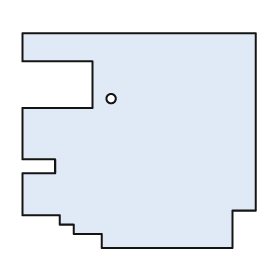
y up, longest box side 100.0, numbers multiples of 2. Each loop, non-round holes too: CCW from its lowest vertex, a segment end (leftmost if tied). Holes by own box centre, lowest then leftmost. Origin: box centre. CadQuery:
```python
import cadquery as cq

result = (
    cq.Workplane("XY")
    .moveTo(-16.0, -46.0)
    .lineTo(40.0, -46.0)
    .lineTo(40.0, -30.0)
    .lineTo(50.0, -30.0)
    .lineTo(50.0, 46.0)
    .lineTo(-50.0, 46.0)
    .lineTo(-50.0, 34.0)
    .lineTo(-20.0, 34.0)
    .lineTo(-20.0, 14.0)
    .lineTo(-50.0, 14.0)
    .lineTo(-50.0, -8.0)
    .lineTo(-36.0, -8.0)
    .lineTo(-36.0, -14.0)
    .lineTo(-50.0, -14.0)
    .lineTo(-50.0, -32.0)
    .lineTo(-34.0, -32.0)
    .lineTo(-34.0, -36.0)
    .lineTo(-28.0, -36.0)
    .lineTo(-28.0, -40.0)
    .lineTo(-16.0, -40.0)
    .close()
    .moveTo(-12.0, 18.0)
    .circle(2.0)
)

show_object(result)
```